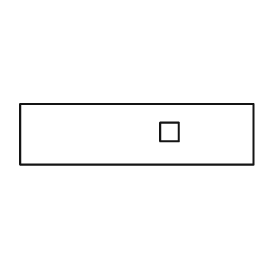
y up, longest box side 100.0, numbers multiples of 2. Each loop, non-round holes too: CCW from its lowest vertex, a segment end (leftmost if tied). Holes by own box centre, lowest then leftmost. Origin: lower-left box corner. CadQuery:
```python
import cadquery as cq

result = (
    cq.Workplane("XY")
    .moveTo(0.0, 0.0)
    .lineTo(100.0, 0.0)
    .lineTo(100.0, 26.0)
    .lineTo(0.0, 26.0)
    .close()
    .moveTo(60.0, 10.0)
    .lineTo(68.0, 10.0)
    .lineTo(68.0, 18.0)
    .lineTo(60.0, 18.0)
    .close()
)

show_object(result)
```